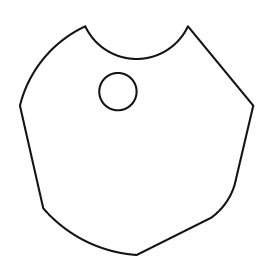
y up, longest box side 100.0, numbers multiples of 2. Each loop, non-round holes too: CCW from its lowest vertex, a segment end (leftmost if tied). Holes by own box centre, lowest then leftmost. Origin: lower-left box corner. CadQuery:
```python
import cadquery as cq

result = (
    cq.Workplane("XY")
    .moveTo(50.0, 0.0)
    .lineTo(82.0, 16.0)
    .threePointArc((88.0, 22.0), (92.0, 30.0))
    .lineTo(100.0, 64.0)
    .lineTo(72.0, 98.0)
    .threePointArc((50.0, 84.0), (28.0, 98.0))
    .threePointArc((10.0, 84.0), (0.0, 64.0))
    .lineTo(10.0, 20.0)
    .threePointArc((28.0, 6.0), (50.0, 0.0))
    .close()
    .moveTo(42.0, 70.0)
    .circle(8.0)
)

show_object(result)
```